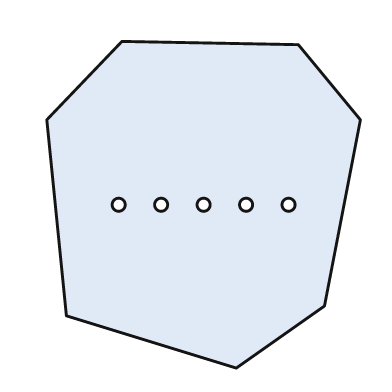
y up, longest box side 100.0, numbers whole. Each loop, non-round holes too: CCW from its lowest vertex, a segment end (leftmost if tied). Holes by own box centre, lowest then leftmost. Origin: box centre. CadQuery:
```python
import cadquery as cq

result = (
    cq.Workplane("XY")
    .moveTo(10.0, -50.0)
    .lineTo(37.0, -31.0)
    .lineTo(48.0, 26.0)
    .lineTo(29.0, 49.0)
    .lineTo(-25.0, 50.0)
    .lineTo(-48.0, 26.0)
    .lineTo(-42.0, -34.0)
    .close()
    .moveTo(-26.0, 0.0)
    .circle(2.0)
    .moveTo(-13.0, 0.0)
    .circle(2.0)
    .moveTo(0.0, 0.0)
    .circle(2.0)
    .moveTo(13.0, 0.0)
    .circle(2.0)
    .moveTo(26.0, 0.0)
    .circle(2.0)
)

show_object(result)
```